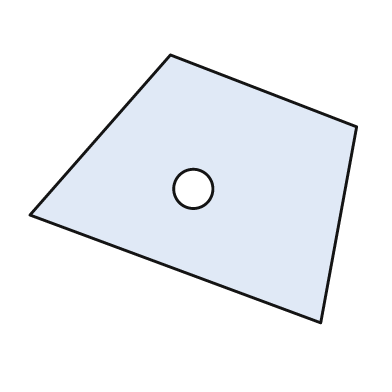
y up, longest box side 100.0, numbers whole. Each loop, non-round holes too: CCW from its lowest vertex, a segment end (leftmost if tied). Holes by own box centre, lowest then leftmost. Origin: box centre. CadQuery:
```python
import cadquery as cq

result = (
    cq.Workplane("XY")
    .moveTo(39.0, -41.0)
    .lineTo(50.0, 19.0)
    .lineTo(-7.0, 41.0)
    .lineTo(-50.0, -8.0)
    .close()
    .moveTo(0.0, 0.0)
    .circle(6.0)
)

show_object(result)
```